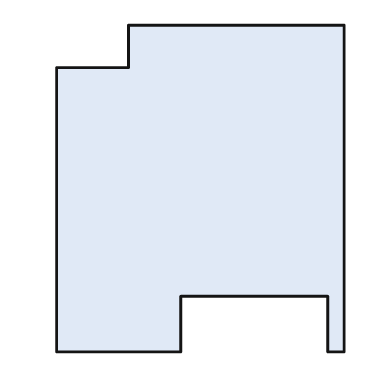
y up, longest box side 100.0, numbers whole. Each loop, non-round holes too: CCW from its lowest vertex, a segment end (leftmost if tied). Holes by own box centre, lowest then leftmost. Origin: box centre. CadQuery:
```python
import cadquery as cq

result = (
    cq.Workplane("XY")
    .moveTo(-44.0, -50.0)
    .lineTo(-6.0, -50.0)
    .lineTo(-6.0, -33.0)
    .lineTo(39.0, -33.0)
    .lineTo(39.0, -50.0)
    .lineTo(44.0, -50.0)
    .lineTo(44.0, 50.0)
    .lineTo(-22.0, 50.0)
    .lineTo(-22.0, 37.0)
    .lineTo(-44.0, 37.0)
    .close()
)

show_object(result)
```